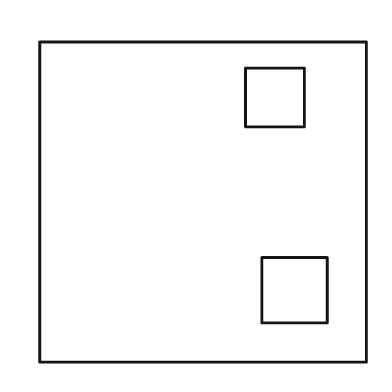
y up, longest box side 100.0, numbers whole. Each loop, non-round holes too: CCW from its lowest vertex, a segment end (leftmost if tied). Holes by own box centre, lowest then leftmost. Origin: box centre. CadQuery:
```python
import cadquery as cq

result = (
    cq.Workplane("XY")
    .moveTo(-50.0, -49.0)
    .lineTo(50.0, -49.0)
    .lineTo(50.0, 49.0)
    .lineTo(-50.0, 49.0)
    .close()
    .moveTo(18.0, -37.0)
    .lineTo(38.0, -37.0)
    .lineTo(38.0, -17.0)
    .lineTo(18.0, -17.0)
    .close()
    .moveTo(13.0, 23.0)
    .lineTo(31.0, 23.0)
    .lineTo(31.0, 41.0)
    .lineTo(13.0, 41.0)
    .close()
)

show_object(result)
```